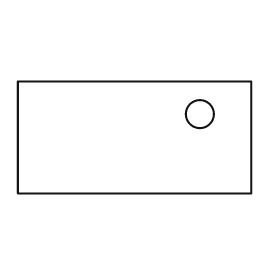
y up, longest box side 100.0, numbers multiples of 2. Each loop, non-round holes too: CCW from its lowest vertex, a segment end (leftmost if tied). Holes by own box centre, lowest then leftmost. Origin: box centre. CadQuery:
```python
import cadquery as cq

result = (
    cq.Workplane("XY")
    .moveTo(-50.0, -24.0)
    .lineTo(50.0, -24.0)
    .lineTo(50.0, 24.0)
    .lineTo(-50.0, 24.0)
    .close()
    .moveTo(28.0, 10.0)
    .circle(6.0)
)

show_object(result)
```